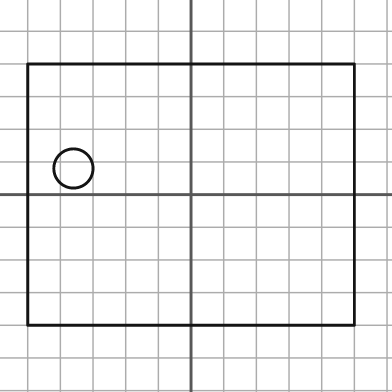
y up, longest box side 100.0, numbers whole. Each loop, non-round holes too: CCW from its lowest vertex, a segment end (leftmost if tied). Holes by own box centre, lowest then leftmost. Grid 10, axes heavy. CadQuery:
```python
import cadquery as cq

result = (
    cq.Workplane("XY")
    .moveTo(-50.0, -40.0)
    .lineTo(50.0, -40.0)
    .lineTo(50.0, 40.0)
    .lineTo(-50.0, 40.0)
    .close()
    .moveTo(-36.0, 8.0)
    .circle(6.0)
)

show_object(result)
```